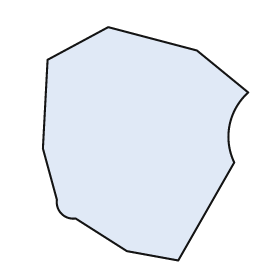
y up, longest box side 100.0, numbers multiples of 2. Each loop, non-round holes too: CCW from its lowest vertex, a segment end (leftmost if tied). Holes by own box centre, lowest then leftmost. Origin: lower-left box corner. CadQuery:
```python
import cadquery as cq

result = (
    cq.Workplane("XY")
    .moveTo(58.0, 0.0)
    .lineTo(82.0, 42.0)
    .threePointArc((80.0, 58.0), (88.0, 72.0))
    .lineTo(66.0, 90.0)
    .lineTo(28.0, 100.0)
    .lineTo(2.0, 86.0)
    .lineTo(0.0, 48.0)
    .lineTo(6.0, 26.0)
    .threePointArc((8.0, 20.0), (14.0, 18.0))
    .lineTo(36.0, 4.0)
    .close()
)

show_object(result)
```